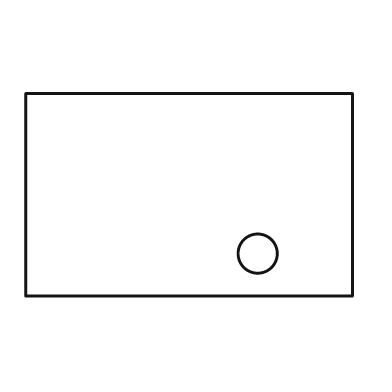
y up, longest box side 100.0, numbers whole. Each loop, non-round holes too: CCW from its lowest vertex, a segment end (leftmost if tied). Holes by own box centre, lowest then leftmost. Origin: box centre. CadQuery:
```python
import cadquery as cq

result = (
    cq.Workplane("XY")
    .moveTo(-50.0, -31.0)
    .lineTo(50.0, -31.0)
    .lineTo(50.0, 31.0)
    .lineTo(-50.0, 31.0)
    .close()
    .moveTo(21.0, -18.0)
    .circle(6.0)
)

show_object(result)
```